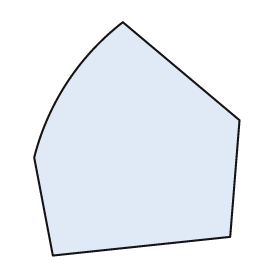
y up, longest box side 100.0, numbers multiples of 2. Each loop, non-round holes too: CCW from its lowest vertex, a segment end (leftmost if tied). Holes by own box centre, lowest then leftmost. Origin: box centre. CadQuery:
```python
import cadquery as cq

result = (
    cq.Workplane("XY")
    .moveTo(-36.0, -50.0)
    .lineTo(40.0, -42.0)
    .lineTo(44.0, 8.0)
    .lineTo(-6.0, 50.0)
    .threePointArc((-30.0, 24.0), (-44.0, -8.0))
    .close()
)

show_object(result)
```